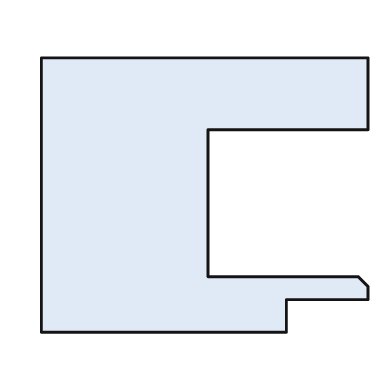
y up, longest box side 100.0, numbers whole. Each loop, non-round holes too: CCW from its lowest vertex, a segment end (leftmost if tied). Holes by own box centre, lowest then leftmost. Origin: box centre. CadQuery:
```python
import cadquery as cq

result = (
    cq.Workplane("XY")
    .moveTo(-50.0, -42.0)
    .lineTo(25.0, -42.0)
    .lineTo(25.0, -32.0)
    .lineTo(50.0, -32.0)
    .lineTo(50.0, -28.0)
    .lineTo(47.0, -25.0)
    .lineTo(1.0, -25.0)
    .lineTo(1.0, 20.0)
    .lineTo(50.0, 20.0)
    .lineTo(50.0, 42.0)
    .lineTo(-50.0, 42.0)
    .close()
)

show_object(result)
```